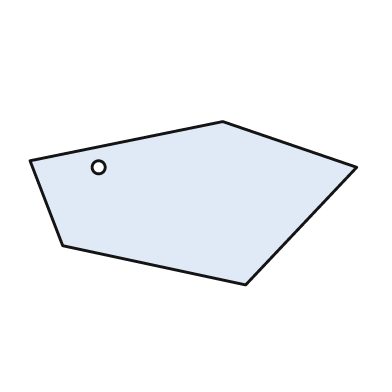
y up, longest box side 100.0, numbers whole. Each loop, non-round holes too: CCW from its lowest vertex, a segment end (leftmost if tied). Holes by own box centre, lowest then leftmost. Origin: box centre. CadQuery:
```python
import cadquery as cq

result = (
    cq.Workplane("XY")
    .moveTo(16.0, -25.0)
    .lineTo(50.0, 11.0)
    .lineTo(9.0, 25.0)
    .lineTo(-50.0, 13.0)
    .lineTo(-40.0, -13.0)
    .close()
    .moveTo(-29.0, 11.0)
    .circle(2.0)
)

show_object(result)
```